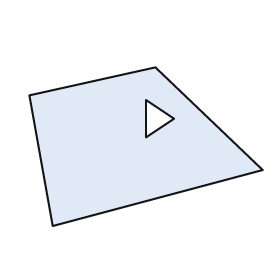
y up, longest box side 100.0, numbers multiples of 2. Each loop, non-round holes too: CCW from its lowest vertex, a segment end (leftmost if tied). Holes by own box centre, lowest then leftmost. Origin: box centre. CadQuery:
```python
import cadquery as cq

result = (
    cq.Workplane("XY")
    .moveTo(-40.0, -34.0)
    .lineTo(50.0, -10.0)
    .lineTo(4.0, 34.0)
    .lineTo(-50.0, 22.0)
    .close()
    .moveTo(0.0, 4.0)
    .lineTo(12.0, 12.0)
    .lineTo(0.0, 20.0)
    .close()
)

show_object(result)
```